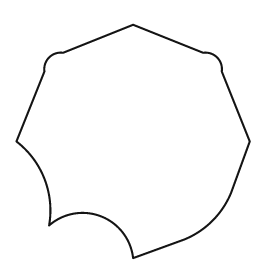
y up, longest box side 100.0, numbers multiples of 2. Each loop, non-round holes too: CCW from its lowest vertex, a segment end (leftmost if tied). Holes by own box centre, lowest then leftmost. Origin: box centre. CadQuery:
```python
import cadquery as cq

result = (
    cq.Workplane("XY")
    .moveTo(0.0, -50.0)
    .lineTo(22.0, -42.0)
    .threePointArc((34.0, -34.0), (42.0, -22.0))
    .lineTo(50.0, 0.0)
    .lineTo(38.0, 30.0)
    .threePointArc((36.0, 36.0), (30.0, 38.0))
    .lineTo(0.0, 50.0)
    .lineTo(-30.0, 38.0)
    .threePointArc((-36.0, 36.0), (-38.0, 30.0))
    .lineTo(-50.0, 0.0)
    .threePointArc((-38.0, -16.0), (-36.0, -36.0))
    .threePointArc((-14.0, -32.0), (0.0, -50.0))
    .close()
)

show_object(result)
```